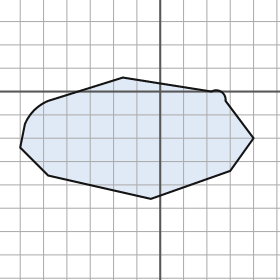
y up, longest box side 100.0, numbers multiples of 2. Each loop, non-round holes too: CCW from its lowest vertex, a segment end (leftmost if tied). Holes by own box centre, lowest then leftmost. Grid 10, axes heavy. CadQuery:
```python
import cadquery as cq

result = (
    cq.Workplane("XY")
    .moveTo(-4.0, -46.0)
    .lineTo(30.0, -34.0)
    .lineTo(40.0, -20.0)
    .lineTo(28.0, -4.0)
    .threePointArc((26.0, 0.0), (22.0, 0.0))
    .lineTo(-16.0, 6.0)
    .lineTo(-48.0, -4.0)
    .threePointArc((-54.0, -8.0), (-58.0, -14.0))
    .lineTo(-60.0, -24.0)
    .lineTo(-48.0, -36.0)
    .close()
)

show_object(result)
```